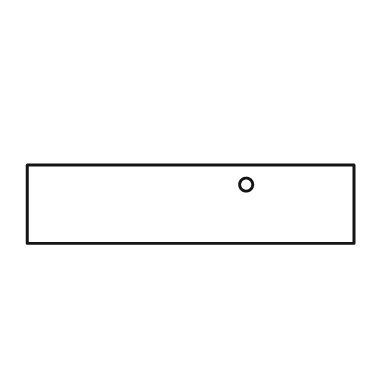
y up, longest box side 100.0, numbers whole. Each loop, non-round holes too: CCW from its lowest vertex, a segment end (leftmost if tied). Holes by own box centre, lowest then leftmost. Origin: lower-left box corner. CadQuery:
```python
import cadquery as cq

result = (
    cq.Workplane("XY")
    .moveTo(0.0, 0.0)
    .lineTo(100.0, 0.0)
    .lineTo(100.0, 24.0)
    .lineTo(0.0, 24.0)
    .close()
    .moveTo(67.0, 18.0)
    .circle(2.0)
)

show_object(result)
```